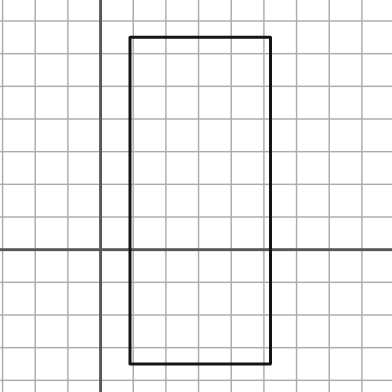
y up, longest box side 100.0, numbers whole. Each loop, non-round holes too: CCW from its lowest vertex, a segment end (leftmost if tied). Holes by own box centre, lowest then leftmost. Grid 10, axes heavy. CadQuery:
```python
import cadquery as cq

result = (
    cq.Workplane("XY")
    .moveTo(9.0, -35.0)
    .lineTo(52.0, -35.0)
    .lineTo(52.0, 65.0)
    .lineTo(9.0, 65.0)
    .close()
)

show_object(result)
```